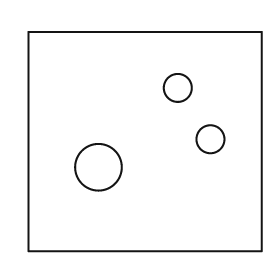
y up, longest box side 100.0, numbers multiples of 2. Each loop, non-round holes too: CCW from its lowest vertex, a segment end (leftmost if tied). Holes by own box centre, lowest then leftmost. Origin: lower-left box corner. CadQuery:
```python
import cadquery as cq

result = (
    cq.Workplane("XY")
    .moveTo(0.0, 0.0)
    .lineTo(100.0, 0.0)
    .lineTo(100.0, 94.0)
    .lineTo(0.0, 94.0)
    .close()
    .moveTo(30.0, 36.0)
    .circle(10.0)
    .moveTo(78.0, 48.0)
    .circle(6.0)
    .moveTo(64.0, 70.0)
    .circle(6.0)
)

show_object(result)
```